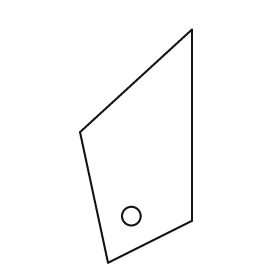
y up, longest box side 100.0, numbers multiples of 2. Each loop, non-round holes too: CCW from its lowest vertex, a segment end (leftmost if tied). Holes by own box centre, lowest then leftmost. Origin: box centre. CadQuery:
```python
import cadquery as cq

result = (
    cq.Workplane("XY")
    .moveTo(-12.0, -50.0)
    .lineTo(24.0, -32.0)
    .lineTo(24.0, 50.0)
    .lineTo(-24.0, 6.0)
    .close()
    .moveTo(-2.0, -30.0)
    .circle(4.0)
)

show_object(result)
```